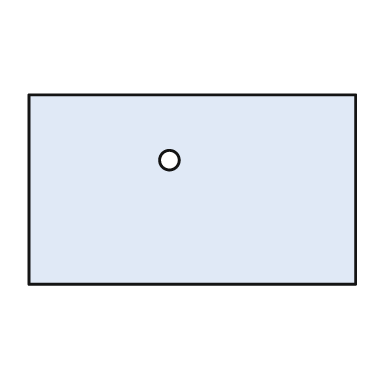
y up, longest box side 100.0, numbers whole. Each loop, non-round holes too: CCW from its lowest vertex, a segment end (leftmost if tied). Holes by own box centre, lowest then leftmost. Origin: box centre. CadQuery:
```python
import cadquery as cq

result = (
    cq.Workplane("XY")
    .moveTo(-50.0, -29.0)
    .lineTo(50.0, -29.0)
    .lineTo(50.0, 29.0)
    .lineTo(-50.0, 29.0)
    .close()
    .moveTo(-7.0, 9.0)
    .circle(3.0)
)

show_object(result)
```